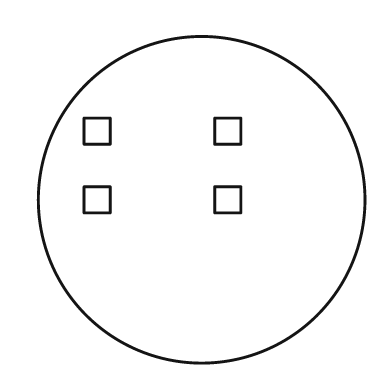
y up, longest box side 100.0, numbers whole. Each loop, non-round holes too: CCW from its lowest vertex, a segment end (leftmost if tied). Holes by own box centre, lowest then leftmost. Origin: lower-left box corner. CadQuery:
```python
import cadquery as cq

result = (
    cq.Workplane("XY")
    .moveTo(50.0, 50.0)
    .circle(50.0)
    .moveTo(14.0, 46.0)
    .lineTo(22.0, 46.0)
    .lineTo(22.0, 54.0)
    .lineTo(14.0, 54.0)
    .close()
    .moveTo(54.0, 46.0)
    .lineTo(62.0, 46.0)
    .lineTo(62.0, 54.0)
    .lineTo(54.0, 54.0)
    .close()
    .moveTo(14.0, 67.0)
    .lineTo(22.0, 67.0)
    .lineTo(22.0, 75.0)
    .lineTo(14.0, 75.0)
    .close()
    .moveTo(54.0, 67.0)
    .lineTo(62.0, 67.0)
    .lineTo(62.0, 75.0)
    .lineTo(54.0, 75.0)
    .close()
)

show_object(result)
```